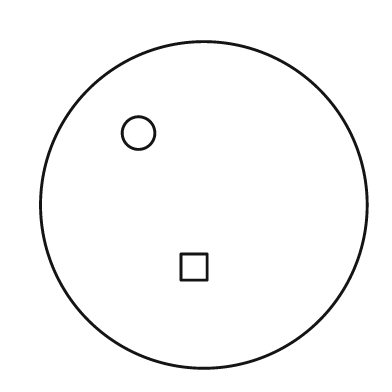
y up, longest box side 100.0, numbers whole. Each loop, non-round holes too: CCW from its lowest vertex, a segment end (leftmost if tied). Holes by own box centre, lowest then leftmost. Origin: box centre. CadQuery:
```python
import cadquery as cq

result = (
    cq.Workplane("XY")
    .moveTo(0.0, 0.0)
    .circle(50.0)
    .moveTo(-7.0, -23.0)
    .lineTo(1.0, -23.0)
    .lineTo(1.0, -15.0)
    .lineTo(-7.0, -15.0)
    .close()
    .moveTo(-20.0, 22.0)
    .circle(5.0)
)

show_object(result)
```